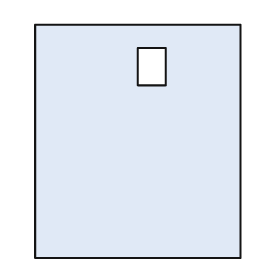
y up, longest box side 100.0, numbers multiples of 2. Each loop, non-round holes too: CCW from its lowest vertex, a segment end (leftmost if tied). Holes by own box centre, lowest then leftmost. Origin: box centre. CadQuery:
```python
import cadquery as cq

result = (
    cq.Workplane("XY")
    .moveTo(-44.0, -50.0)
    .lineTo(44.0, -50.0)
    .lineTo(44.0, 50.0)
    .lineTo(-44.0, 50.0)
    .close()
    .moveTo(0.0, 24.0)
    .lineTo(12.0, 24.0)
    .lineTo(12.0, 40.0)
    .lineTo(0.0, 40.0)
    .close()
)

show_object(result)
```